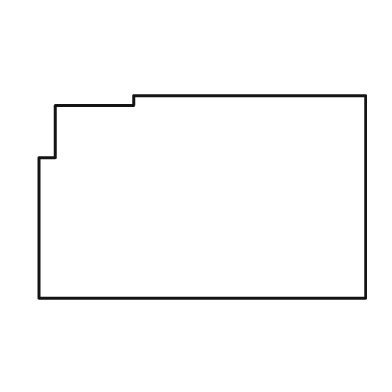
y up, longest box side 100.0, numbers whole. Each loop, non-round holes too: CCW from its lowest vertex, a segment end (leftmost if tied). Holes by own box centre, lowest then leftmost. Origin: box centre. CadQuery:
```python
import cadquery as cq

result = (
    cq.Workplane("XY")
    .moveTo(-50.0, -31.0)
    .lineTo(50.0, -31.0)
    .lineTo(50.0, 31.0)
    .lineTo(-21.0, 31.0)
    .lineTo(-21.0, 28.0)
    .lineTo(-45.0, 28.0)
    .lineTo(-45.0, 12.0)
    .lineTo(-50.0, 12.0)
    .close()
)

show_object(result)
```